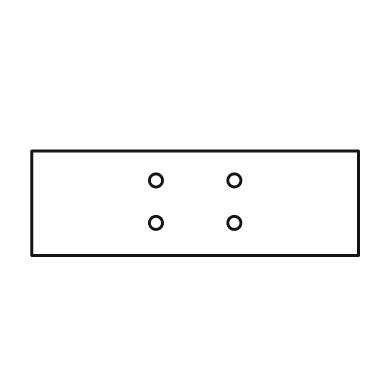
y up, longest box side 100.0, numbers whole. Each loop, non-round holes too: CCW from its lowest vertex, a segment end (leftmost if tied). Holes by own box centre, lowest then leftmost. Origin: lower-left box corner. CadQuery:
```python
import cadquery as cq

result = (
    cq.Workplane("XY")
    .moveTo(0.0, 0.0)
    .lineTo(100.0, 0.0)
    .lineTo(100.0, 32.0)
    .lineTo(0.0, 32.0)
    .close()
    .moveTo(38.0, 10.0)
    .circle(2.0)
    .moveTo(62.0, 10.0)
    .circle(2.0)
    .moveTo(38.0, 23.0)
    .circle(2.0)
    .moveTo(62.0, 23.0)
    .circle(2.0)
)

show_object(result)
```